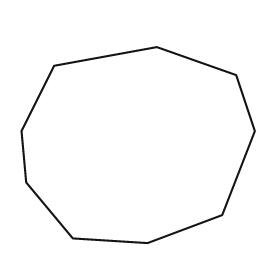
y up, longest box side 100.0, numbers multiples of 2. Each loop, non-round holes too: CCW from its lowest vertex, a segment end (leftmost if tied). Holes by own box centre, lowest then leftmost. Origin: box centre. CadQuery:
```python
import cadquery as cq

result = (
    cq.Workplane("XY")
    .moveTo(4.0, -42.0)
    .lineTo(36.0, -30.0)
    .lineTo(50.0, 6.0)
    .lineTo(42.0, 30.0)
    .lineTo(8.0, 42.0)
    .lineTo(-36.0, 34.0)
    .lineTo(-50.0, 6.0)
    .lineTo(-48.0, -16.0)
    .lineTo(-28.0, -40.0)
    .close()
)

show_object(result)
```